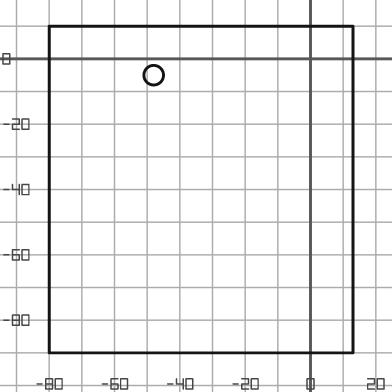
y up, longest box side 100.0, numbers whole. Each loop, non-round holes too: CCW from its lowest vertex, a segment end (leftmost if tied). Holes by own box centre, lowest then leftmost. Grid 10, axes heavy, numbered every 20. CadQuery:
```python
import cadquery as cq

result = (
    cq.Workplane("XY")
    .moveTo(-80.0, -90.0)
    .lineTo(13.0, -90.0)
    .lineTo(13.0, 10.0)
    .lineTo(-80.0, 10.0)
    .close()
    .moveTo(-48.0, -5.0)
    .circle(3.0)
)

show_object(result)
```